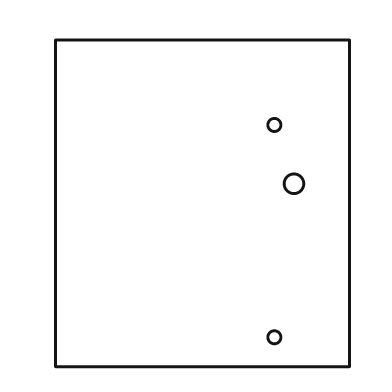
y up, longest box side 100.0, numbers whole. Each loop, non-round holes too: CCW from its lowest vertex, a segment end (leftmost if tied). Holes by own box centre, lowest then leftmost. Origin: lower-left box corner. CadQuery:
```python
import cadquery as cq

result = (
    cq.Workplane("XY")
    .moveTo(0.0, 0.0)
    .lineTo(90.0, 0.0)
    .lineTo(90.0, 100.0)
    .lineTo(0.0, 100.0)
    .close()
    .moveTo(67.0, 9.0)
    .circle(2.0)
    .moveTo(73.0, 56.0)
    .circle(3.0)
    .moveTo(67.0, 74.0)
    .circle(2.0)
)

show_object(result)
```